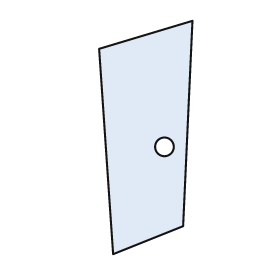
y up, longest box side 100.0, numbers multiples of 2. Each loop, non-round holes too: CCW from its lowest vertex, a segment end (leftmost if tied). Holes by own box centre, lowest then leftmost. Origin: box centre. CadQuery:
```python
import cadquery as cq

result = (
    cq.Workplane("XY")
    .moveTo(-14.0, -50.0)
    .lineTo(16.0, -38.0)
    .lineTo(20.0, 50.0)
    .lineTo(-20.0, 38.0)
    .close()
    .moveTo(8.0, -4.0)
    .circle(4.0)
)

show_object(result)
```